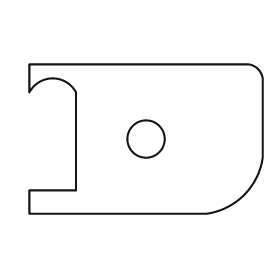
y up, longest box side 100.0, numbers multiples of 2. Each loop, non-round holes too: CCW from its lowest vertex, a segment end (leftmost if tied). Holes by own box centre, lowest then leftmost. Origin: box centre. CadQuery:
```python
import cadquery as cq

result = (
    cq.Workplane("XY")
    .moveTo(-50.0, -32.0)
    .lineTo(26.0, -32.0)
    .threePointArc((42.0, -24.0), (50.0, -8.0))
    .lineTo(50.0, 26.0)
    .threePointArc((48.0, 30.0), (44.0, 32.0))
    .lineTo(-50.0, 32.0)
    .lineTo(-50.0, 20.0)
    .threePointArc((-40.0, 26.0), (-30.0, 20.0))
    .lineTo(-30.0, -22.0)
    .lineTo(-50.0, -22.0)
    .close()
    .moveTo(0.0, 0.0)
    .circle(8.0)
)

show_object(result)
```